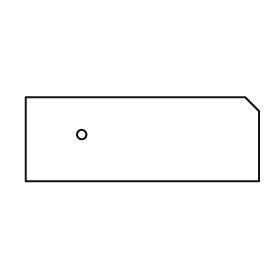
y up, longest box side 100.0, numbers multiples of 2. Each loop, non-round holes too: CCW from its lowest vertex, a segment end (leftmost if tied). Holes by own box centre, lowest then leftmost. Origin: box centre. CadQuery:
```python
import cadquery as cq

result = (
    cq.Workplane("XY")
    .moveTo(-50.0, -18.0)
    .lineTo(50.0, -18.0)
    .lineTo(50.0, 12.0)
    .lineTo(44.0, 18.0)
    .lineTo(-50.0, 18.0)
    .close()
    .moveTo(-26.0, 2.0)
    .circle(2.0)
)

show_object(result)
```